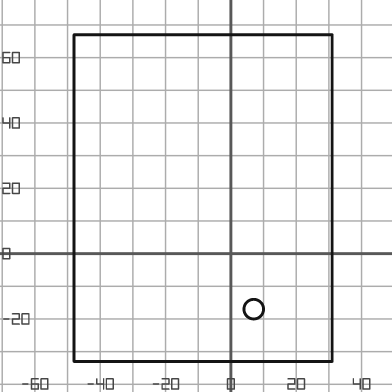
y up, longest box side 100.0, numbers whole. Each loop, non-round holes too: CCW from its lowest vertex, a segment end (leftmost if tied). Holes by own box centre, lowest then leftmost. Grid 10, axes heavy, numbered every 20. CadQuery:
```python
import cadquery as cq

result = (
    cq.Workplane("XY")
    .moveTo(-48.0, -33.0)
    .lineTo(31.0, -33.0)
    .lineTo(31.0, 67.0)
    .lineTo(-48.0, 67.0)
    .close()
    .moveTo(7.0, -17.0)
    .circle(3.0)
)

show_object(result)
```